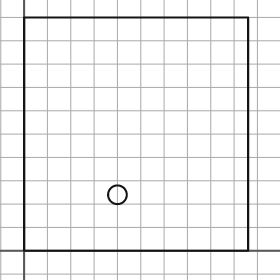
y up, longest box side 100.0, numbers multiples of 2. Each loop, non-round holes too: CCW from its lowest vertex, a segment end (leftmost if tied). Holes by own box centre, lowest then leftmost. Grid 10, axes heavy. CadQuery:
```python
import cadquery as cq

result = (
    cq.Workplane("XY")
    .moveTo(0.0, 0.0)
    .lineTo(96.0, 0.0)
    .lineTo(96.0, 100.0)
    .lineTo(0.0, 100.0)
    .close()
    .moveTo(40.0, 24.0)
    .circle(4.0)
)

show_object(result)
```